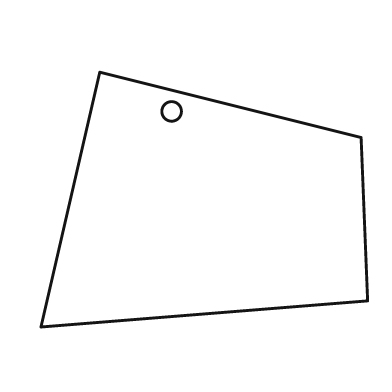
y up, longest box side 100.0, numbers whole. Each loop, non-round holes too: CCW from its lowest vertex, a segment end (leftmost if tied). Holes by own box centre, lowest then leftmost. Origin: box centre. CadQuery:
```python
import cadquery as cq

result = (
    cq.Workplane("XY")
    .moveTo(-50.0, -39.0)
    .lineTo(50.0, -31.0)
    .lineTo(48.0, 19.0)
    .lineTo(-32.0, 39.0)
    .close()
    .moveTo(-10.0, 27.0)
    .circle(3.0)
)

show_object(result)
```